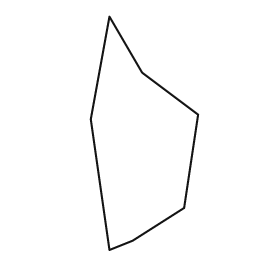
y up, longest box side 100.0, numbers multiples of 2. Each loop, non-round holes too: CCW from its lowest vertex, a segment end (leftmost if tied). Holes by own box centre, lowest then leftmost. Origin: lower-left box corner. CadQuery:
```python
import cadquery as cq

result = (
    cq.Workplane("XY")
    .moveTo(8.0, 0.0)
    .lineTo(18.0, 4.0)
    .lineTo(40.0, 18.0)
    .lineTo(46.0, 58.0)
    .lineTo(22.0, 76.0)
    .lineTo(8.0, 100.0)
    .lineTo(0.0, 56.0)
    .close()
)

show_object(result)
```